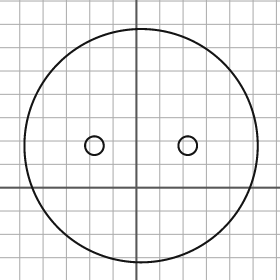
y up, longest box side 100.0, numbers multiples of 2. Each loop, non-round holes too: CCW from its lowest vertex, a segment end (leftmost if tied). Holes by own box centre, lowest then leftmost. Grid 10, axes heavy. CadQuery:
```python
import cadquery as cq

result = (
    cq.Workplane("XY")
    .moveTo(2.0, 18.0)
    .circle(50.0)
    .moveTo(-18.0, 18.0)
    .circle(4.0)
    .moveTo(22.0, 18.0)
    .circle(4.0)
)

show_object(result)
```